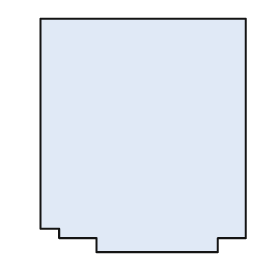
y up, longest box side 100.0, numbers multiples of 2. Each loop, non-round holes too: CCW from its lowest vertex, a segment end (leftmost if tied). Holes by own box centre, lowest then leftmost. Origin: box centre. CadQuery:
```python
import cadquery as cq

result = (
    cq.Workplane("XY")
    .moveTo(-20.0, -50.0)
    .lineTo(32.0, -50.0)
    .lineTo(32.0, -44.0)
    .lineTo(44.0, -44.0)
    .lineTo(44.0, 50.0)
    .lineTo(-44.0, 50.0)
    .lineTo(-44.0, -40.0)
    .lineTo(-36.0, -40.0)
    .lineTo(-36.0, -44.0)
    .lineTo(-20.0, -44.0)
    .close()
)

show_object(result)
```